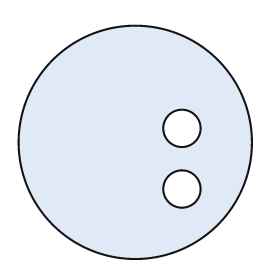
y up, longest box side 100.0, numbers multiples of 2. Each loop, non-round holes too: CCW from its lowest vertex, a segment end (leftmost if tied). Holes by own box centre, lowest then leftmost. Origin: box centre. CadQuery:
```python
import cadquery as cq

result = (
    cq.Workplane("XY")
    .moveTo(0.0, 0.0)
    .circle(50.0)
    .moveTo(20.0, -20.0)
    .circle(8.0)
    .moveTo(20.0, 6.0)
    .circle(8.0)
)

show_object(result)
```